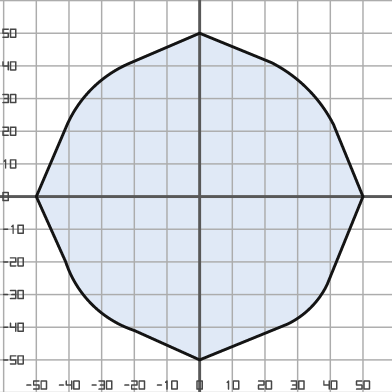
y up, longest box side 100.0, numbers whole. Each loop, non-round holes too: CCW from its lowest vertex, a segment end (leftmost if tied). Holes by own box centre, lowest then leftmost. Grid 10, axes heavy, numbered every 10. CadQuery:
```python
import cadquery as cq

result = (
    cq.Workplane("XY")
    .moveTo(0.0, -50.0)
    .lineTo(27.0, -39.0)
    .threePointArc((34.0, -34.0), (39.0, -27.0))
    .lineTo(50.0, 0.0)
    .lineTo(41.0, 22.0)
    .threePointArc((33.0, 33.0), (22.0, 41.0))
    .lineTo(0.0, 50.0)
    .lineTo(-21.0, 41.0)
    .threePointArc((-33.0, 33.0), (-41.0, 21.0))
    .lineTo(-50.0, 0.0)
    .lineTo(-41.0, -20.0)
    .threePointArc((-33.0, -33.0), (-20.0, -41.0))
    .close()
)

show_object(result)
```